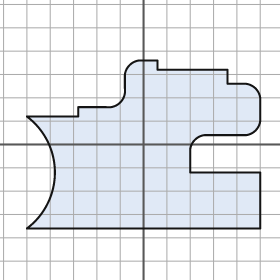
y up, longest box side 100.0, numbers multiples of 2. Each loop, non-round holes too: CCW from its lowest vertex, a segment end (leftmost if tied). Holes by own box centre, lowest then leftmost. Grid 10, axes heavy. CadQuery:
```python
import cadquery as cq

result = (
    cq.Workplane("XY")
    .moveTo(-50.0, -36.0)
    .lineTo(50.0, -36.0)
    .lineTo(50.0, -12.0)
    .lineTo(20.0, -12.0)
    .lineTo(20.0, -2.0)
    .threePointArc((22.0, 2.0), (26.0, 4.0))
    .lineTo(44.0, 4.0)
    .threePointArc((48.0, 6.0), (50.0, 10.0))
    .lineTo(50.0, 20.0)
    .threePointArc((48.0, 24.0), (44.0, 26.0))
    .lineTo(36.0, 26.0)
    .lineTo(36.0, 32.0)
    .lineTo(6.0, 32.0)
    .lineTo(6.0, 36.0)
    .lineTo(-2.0, 36.0)
    .threePointArc((-6.0, 34.0), (-8.0, 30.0))
    .lineTo(-8.0, 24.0)
    .threePointArc((-10.0, 18.0), (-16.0, 16.0))
    .lineTo(-28.0, 16.0)
    .lineTo(-28.0, 12.0)
    .lineTo(-50.0, 12.0)
    .threePointArc((-38.0, -12.0), (-50.0, -36.0))
    .close()
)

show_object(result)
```